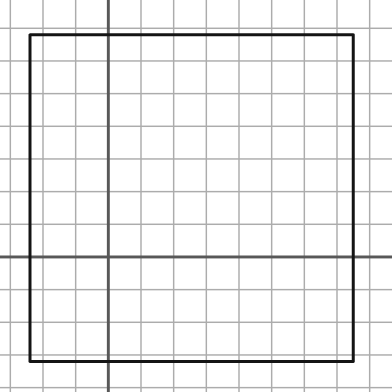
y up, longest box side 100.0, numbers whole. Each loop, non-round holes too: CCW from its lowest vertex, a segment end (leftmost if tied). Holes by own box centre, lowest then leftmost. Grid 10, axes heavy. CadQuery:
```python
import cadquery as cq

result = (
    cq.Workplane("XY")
    .moveTo(-24.0, -32.0)
    .lineTo(75.0, -32.0)
    .lineTo(75.0, 68.0)
    .lineTo(-24.0, 68.0)
    .close()
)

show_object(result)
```